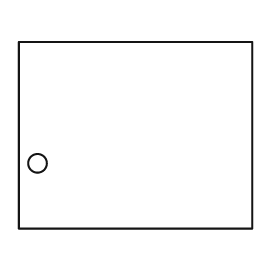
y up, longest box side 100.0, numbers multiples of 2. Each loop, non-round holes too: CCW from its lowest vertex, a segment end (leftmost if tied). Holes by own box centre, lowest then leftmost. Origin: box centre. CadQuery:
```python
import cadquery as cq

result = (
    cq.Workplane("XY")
    .moveTo(-50.0, -40.0)
    .lineTo(50.0, -40.0)
    .lineTo(50.0, 40.0)
    .lineTo(-50.0, 40.0)
    .close()
    .moveTo(-42.0, -12.0)
    .circle(4.0)
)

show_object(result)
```